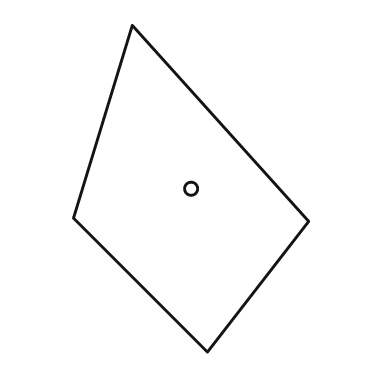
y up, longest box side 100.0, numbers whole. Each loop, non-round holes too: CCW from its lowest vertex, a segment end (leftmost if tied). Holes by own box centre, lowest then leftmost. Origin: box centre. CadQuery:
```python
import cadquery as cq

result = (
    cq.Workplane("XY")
    .moveTo(5.0, -50.0)
    .lineTo(36.0, -10.0)
    .lineTo(-18.0, 50.0)
    .lineTo(-36.0, -9.0)
    .close()
    .moveTo(0.0, 0.0)
    .circle(2.0)
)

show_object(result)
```